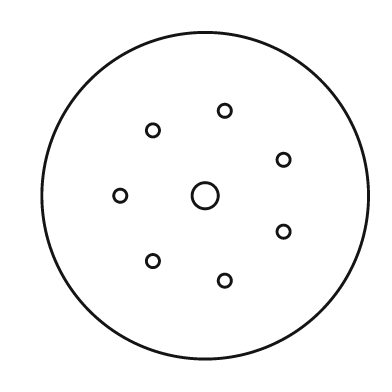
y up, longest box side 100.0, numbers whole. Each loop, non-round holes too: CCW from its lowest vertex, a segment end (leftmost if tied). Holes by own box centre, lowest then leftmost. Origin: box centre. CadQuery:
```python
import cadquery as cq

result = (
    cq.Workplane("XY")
    .moveTo(0.0, 0.0)
    .circle(50.0)
    .moveTo(6.0, -26.0)
    .circle(2.0)
    .moveTo(-16.0, -20.0)
    .circle(2.0)
    .moveTo(24.0, -11.0)
    .circle(2.0)
    .moveTo(-26.0, 0.0)
    .circle(2.0)
    .moveTo(0.0, 0.0)
    .circle(4.0)
    .moveTo(24.0, 11.0)
    .circle(2.0)
    .moveTo(-16.0, 20.0)
    .circle(2.0)
    .moveTo(6.0, 26.0)
    .circle(2.0)
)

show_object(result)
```